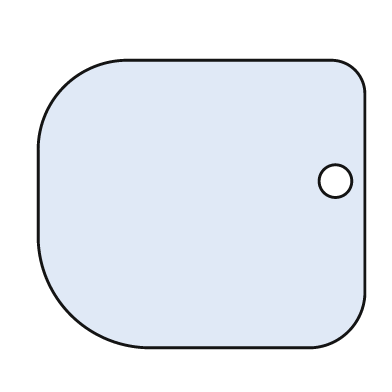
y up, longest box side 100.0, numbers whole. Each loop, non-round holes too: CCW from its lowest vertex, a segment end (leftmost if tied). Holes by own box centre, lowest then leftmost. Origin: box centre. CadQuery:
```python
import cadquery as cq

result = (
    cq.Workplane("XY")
    .moveTo(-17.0, -44.0)
    .lineTo(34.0, -44.0)
    .threePointArc((45.0, -39.0), (50.0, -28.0))
    .lineTo(50.0, 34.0)
    .threePointArc((47.0, 41.0), (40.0, 44.0))
    .lineTo(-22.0, 44.0)
    .threePointArc((-42.0, 36.0), (-50.0, 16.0))
    .lineTo(-50.0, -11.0)
    .threePointArc((-40.0, -34.0), (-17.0, -44.0))
    .close()
    .moveTo(41.0, 7.0)
    .circle(5.0)
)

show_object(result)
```